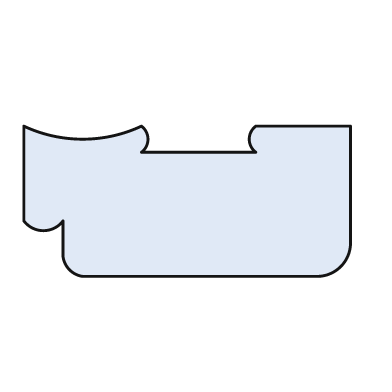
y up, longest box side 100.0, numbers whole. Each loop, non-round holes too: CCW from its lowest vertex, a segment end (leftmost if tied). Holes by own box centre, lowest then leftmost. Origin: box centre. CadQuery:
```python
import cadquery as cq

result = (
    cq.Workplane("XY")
    .moveTo(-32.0, -23.0)
    .lineTo(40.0, -23.0)
    .threePointArc((47.0, -20.0), (50.0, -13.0))
    .lineTo(50.0, 23.0)
    .lineTo(21.0, 23.0)
    .threePointArc((19.0, 19.0), (21.0, 15.0))
    .lineTo(-14.0, 15.0)
    .threePointArc((-12.0, 19.0), (-14.0, 23.0))
    .threePointArc((-32.0, 19.0), (-50.0, 23.0))
    .lineTo(-50.0, -6.0)
    .threePointArc((-44.0, -9.0), (-38.0, -6.0))
    .lineTo(-38.0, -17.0)
    .threePointArc((-36.0, -21.0), (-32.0, -23.0))
    .close()
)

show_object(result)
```